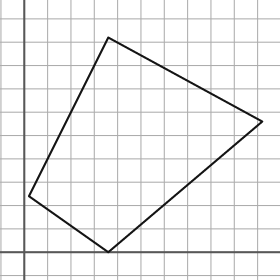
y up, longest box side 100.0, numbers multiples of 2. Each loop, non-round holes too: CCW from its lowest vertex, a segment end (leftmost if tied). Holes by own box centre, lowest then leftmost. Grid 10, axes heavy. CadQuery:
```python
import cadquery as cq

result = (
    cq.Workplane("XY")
    .moveTo(36.0, 0.0)
    .lineTo(102.0, 56.0)
    .lineTo(36.0, 92.0)
    .lineTo(2.0, 24.0)
    .close()
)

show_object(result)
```